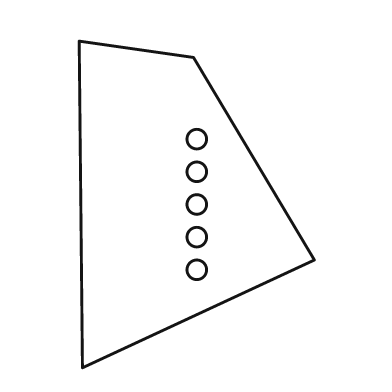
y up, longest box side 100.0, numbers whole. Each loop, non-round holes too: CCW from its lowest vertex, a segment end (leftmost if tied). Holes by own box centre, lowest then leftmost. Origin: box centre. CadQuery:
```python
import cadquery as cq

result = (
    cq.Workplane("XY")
    .moveTo(-35.0, -50.0)
    .lineTo(36.0, -17.0)
    .lineTo(-1.0, 45.0)
    .lineTo(-36.0, 50.0)
    .close()
    .moveTo(0.0, -20.0)
    .circle(3.0)
    .moveTo(0.0, -10.0)
    .circle(3.0)
    .moveTo(0.0, 0.0)
    .circle(3.0)
    .moveTo(0.0, 10.0)
    .circle(3.0)
    .moveTo(0.0, 20.0)
    .circle(3.0)
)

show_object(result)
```